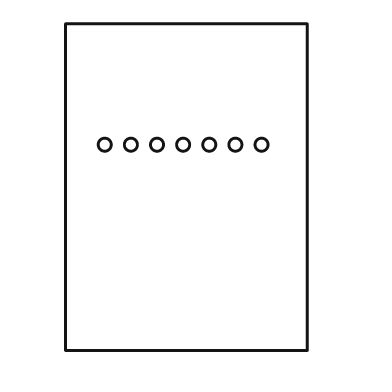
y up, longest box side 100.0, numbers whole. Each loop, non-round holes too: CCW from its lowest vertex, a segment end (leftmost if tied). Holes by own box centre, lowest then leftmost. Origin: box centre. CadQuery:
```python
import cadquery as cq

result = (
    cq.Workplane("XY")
    .moveTo(-37.0, -50.0)
    .lineTo(37.0, -50.0)
    .lineTo(37.0, 50.0)
    .lineTo(-37.0, 50.0)
    .close()
    .moveTo(-25.0, 13.0)
    .circle(2.0)
    .moveTo(-17.0, 13.0)
    .circle(2.0)
    .moveTo(-9.0, 13.0)
    .circle(2.0)
    .moveTo(-1.0, 13.0)
    .circle(2.0)
    .moveTo(7.0, 13.0)
    .circle(2.0)
    .moveTo(15.0, 13.0)
    .circle(2.0)
    .moveTo(23.0, 13.0)
    .circle(2.0)
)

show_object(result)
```